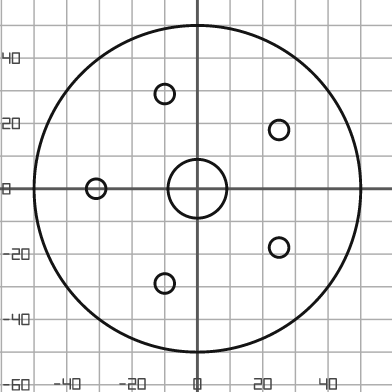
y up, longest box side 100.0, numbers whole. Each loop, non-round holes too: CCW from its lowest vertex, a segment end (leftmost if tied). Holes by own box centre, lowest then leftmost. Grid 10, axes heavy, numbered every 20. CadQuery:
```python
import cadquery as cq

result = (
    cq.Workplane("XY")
    .moveTo(0.0, 0.0)
    .circle(50.0)
    .moveTo(-10.0, -29.0)
    .circle(3.0)
    .moveTo(25.0, -18.0)
    .circle(3.0)
    .moveTo(-31.0, 0.0)
    .circle(3.0)
    .moveTo(0.0, 0.0)
    .circle(9.0)
    .moveTo(25.0, 18.0)
    .circle(3.0)
    .moveTo(-10.0, 29.0)
    .circle(3.0)
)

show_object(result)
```